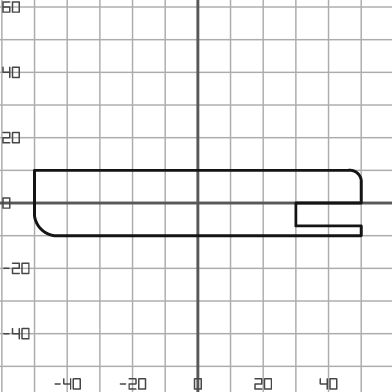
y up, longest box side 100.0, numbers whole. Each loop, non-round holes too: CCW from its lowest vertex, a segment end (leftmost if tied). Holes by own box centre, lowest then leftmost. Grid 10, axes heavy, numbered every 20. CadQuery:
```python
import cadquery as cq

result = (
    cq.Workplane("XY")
    .moveTo(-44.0, -10.0)
    .lineTo(50.0, -10.0)
    .lineTo(50.0, -7.0)
    .lineTo(30.0, -7.0)
    .lineTo(30.0, 0.0)
    .lineTo(50.0, 0.0)
    .lineTo(50.0, 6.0)
    .threePointArc((49.0, 9.0), (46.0, 10.0))
    .lineTo(-50.0, 10.0)
    .lineTo(-50.0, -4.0)
    .threePointArc((-48.0, -8.0), (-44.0, -10.0))
    .close()
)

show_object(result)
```